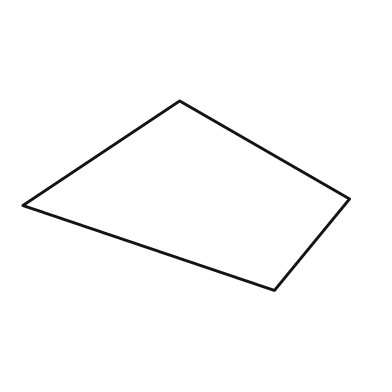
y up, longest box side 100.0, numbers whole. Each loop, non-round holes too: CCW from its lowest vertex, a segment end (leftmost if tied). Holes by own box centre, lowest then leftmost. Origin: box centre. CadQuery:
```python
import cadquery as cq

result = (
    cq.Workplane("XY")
    .moveTo(27.0, -29.0)
    .lineTo(50.0, -1.0)
    .lineTo(-2.0, 29.0)
    .lineTo(-50.0, -3.0)
    .close()
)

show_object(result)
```